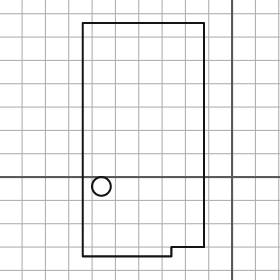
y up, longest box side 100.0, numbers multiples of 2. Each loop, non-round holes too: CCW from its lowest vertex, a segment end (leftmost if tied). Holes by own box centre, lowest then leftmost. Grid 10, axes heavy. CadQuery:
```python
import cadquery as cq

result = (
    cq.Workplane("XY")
    .moveTo(-64.0, -34.0)
    .lineTo(-26.0, -34.0)
    .lineTo(-26.0, -30.0)
    .lineTo(-12.0, -30.0)
    .lineTo(-12.0, 66.0)
    .lineTo(-64.0, 66.0)
    .close()
    .moveTo(-56.0, -4.0)
    .circle(4.0)
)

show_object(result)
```